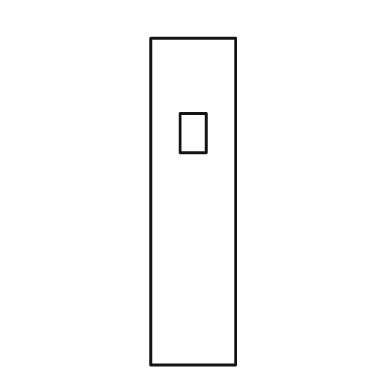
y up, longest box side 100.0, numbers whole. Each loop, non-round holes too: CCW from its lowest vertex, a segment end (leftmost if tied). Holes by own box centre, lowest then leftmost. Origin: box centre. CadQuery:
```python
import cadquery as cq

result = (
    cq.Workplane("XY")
    .moveTo(-13.0, -50.0)
    .lineTo(13.0, -50.0)
    .lineTo(13.0, 50.0)
    .lineTo(-13.0, 50.0)
    .close()
    .moveTo(-4.0, 15.0)
    .lineTo(4.0, 15.0)
    .lineTo(4.0, 27.0)
    .lineTo(-4.0, 27.0)
    .close()
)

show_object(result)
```